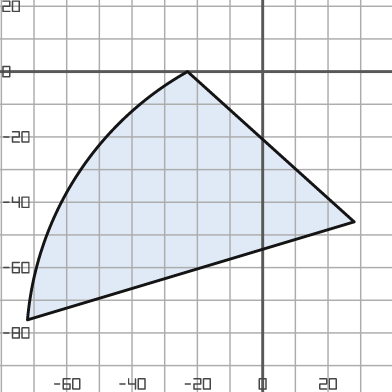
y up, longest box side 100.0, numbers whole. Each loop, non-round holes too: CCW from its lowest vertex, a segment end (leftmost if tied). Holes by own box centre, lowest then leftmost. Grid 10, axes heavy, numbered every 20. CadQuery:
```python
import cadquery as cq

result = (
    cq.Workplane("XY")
    .moveTo(-72.0, -76.0)
    .lineTo(28.0, -46.0)
    .lineTo(-23.0, 0.0)
    .threePointArc((-57.0, -32.0), (-72.0, -76.0))
    .close()
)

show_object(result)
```